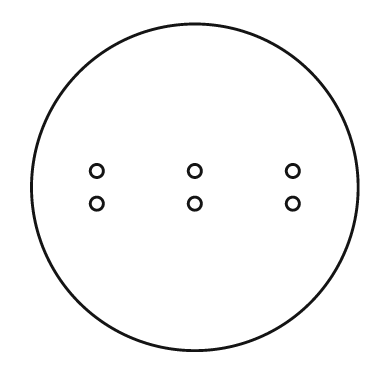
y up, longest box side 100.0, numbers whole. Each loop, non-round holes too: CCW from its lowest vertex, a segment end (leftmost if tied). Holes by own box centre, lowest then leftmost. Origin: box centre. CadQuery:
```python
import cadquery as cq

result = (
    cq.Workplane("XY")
    .moveTo(0.0, 0.0)
    .circle(50.0)
    .moveTo(-30.0, -5.0)
    .circle(2.0)
    .moveTo(0.0, -5.0)
    .circle(2.0)
    .moveTo(30.0, -5.0)
    .circle(2.0)
    .moveTo(-30.0, 5.0)
    .circle(2.0)
    .moveTo(0.0, 5.0)
    .circle(2.0)
    .moveTo(30.0, 5.0)
    .circle(2.0)
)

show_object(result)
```